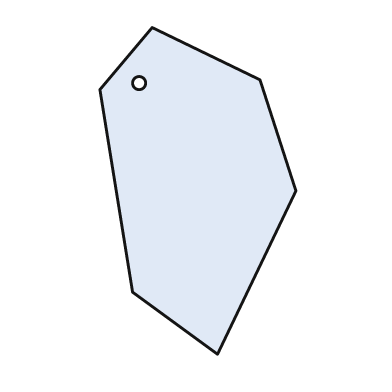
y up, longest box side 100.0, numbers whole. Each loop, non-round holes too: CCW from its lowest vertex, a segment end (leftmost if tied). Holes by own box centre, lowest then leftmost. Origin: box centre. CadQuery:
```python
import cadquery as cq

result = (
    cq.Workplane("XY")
    .moveTo(6.0, -50.0)
    .lineTo(30.0, 0.0)
    .lineTo(19.0, 34.0)
    .lineTo(-14.0, 50.0)
    .lineTo(-30.0, 31.0)
    .lineTo(-20.0, -31.0)
    .close()
    .moveTo(-18.0, 33.0)
    .circle(2.0)
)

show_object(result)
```